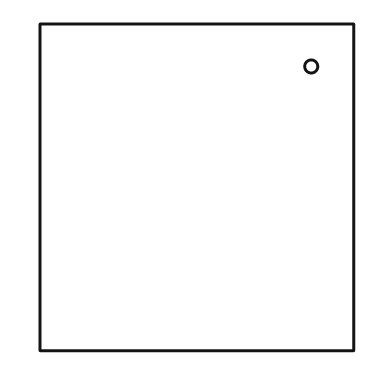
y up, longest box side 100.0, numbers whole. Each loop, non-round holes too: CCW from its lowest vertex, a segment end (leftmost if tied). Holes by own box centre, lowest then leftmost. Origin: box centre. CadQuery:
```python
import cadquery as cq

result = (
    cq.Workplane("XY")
    .moveTo(-48.0, -50.0)
    .lineTo(48.0, -50.0)
    .lineTo(48.0, 50.0)
    .lineTo(-48.0, 50.0)
    .close()
    .moveTo(35.0, 37.0)
    .circle(2.0)
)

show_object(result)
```